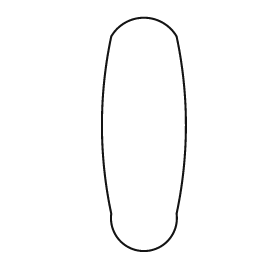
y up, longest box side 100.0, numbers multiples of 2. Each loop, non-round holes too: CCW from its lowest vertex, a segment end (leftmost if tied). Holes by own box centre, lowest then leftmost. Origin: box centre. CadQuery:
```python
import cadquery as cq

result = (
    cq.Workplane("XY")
    .moveTo(-14.0, -34.0)
    .threePointArc((0.0, -50.0), (14.0, -34.0))
    .threePointArc((18.0, 4.0), (14.0, 42.0))
    .threePointArc((0.0, 50.0), (-14.0, 42.0))
    .threePointArc((-18.0, 4.0), (-14.0, -34.0))
    .close()
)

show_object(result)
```